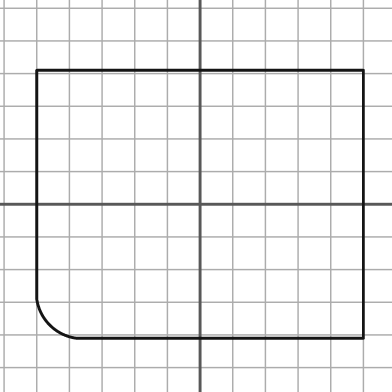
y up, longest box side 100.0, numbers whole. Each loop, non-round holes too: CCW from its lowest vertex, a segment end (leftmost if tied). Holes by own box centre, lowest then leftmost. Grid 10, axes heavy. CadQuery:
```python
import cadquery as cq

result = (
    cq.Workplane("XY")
    .moveTo(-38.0, -41.0)
    .lineTo(50.0, -41.0)
    .lineTo(50.0, 41.0)
    .lineTo(-50.0, 41.0)
    .lineTo(-50.0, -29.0)
    .threePointArc((-46.0, -37.0), (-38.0, -41.0))
    .close()
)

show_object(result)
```